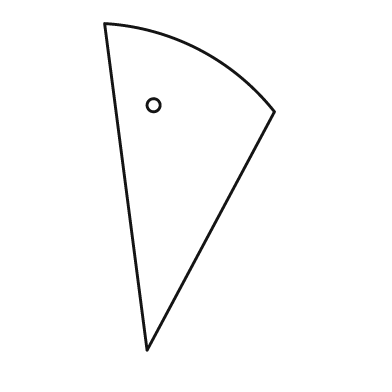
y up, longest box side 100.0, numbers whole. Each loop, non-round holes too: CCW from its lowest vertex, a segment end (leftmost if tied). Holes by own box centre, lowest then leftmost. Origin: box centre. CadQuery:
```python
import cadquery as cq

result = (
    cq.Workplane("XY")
    .moveTo(-13.0, -50.0)
    .lineTo(26.0, 23.0)
    .threePointArc((3.0, 42.0), (-26.0, 50.0))
    .close()
    .moveTo(-11.0, 25.0)
    .circle(2.0)
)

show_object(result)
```